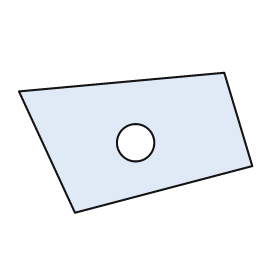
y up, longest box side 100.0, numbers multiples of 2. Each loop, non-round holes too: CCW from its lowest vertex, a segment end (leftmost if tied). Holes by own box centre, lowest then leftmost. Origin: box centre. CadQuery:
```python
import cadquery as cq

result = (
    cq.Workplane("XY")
    .moveTo(-26.0, -30.0)
    .lineTo(50.0, -10.0)
    .lineTo(38.0, 30.0)
    .lineTo(-50.0, 22.0)
    .close()
    .moveTo(0.0, 0.0)
    .circle(8.0)
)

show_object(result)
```